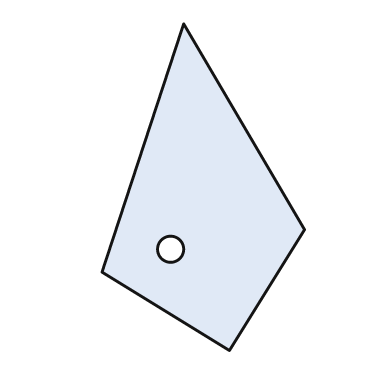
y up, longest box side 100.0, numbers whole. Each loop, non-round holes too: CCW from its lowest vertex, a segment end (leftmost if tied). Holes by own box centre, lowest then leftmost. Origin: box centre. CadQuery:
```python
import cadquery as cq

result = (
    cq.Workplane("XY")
    .moveTo(8.0, -50.0)
    .lineTo(31.0, -13.0)
    .lineTo(-6.0, 50.0)
    .lineTo(-31.0, -26.0)
    .close()
    .moveTo(-10.0, -19.0)
    .circle(4.0)
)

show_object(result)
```